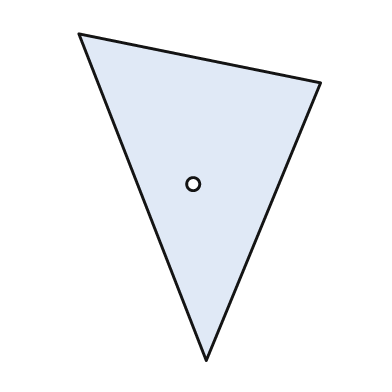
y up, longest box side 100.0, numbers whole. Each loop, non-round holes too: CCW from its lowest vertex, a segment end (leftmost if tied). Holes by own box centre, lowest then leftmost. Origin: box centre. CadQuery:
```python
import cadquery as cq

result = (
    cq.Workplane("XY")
    .moveTo(2.0, -50.0)
    .lineTo(37.0, 35.0)
    .lineTo(-37.0, 50.0)
    .close()
    .moveTo(-2.0, 4.0)
    .circle(2.0)
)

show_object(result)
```